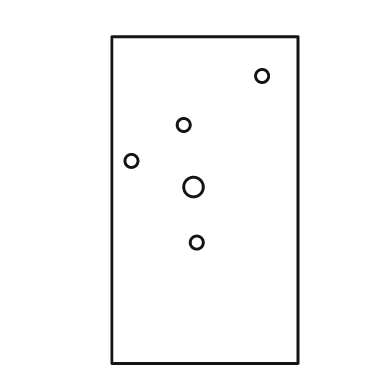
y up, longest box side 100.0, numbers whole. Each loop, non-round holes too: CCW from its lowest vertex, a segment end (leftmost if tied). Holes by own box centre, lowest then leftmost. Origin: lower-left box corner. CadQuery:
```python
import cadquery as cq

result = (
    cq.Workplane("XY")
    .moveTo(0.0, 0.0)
    .lineTo(57.0, 0.0)
    .lineTo(57.0, 100.0)
    .lineTo(0.0, 100.0)
    .close()
    .moveTo(26.0, 37.0)
    .circle(2.0)
    .moveTo(25.0, 54.0)
    .circle(3.0)
    .moveTo(6.0, 62.0)
    .circle(2.0)
    .moveTo(22.0, 73.0)
    .circle(2.0)
    .moveTo(46.0, 88.0)
    .circle(2.0)
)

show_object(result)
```